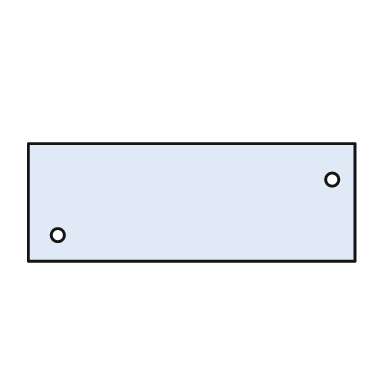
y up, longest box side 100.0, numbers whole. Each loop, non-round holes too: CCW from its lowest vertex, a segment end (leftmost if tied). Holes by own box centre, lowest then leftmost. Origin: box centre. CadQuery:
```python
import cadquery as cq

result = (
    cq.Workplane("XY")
    .moveTo(-50.0, -18.0)
    .lineTo(50.0, -18.0)
    .lineTo(50.0, 18.0)
    .lineTo(-50.0, 18.0)
    .close()
    .moveTo(-41.0, -10.0)
    .circle(2.0)
    .moveTo(43.0, 7.0)
    .circle(2.0)
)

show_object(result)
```